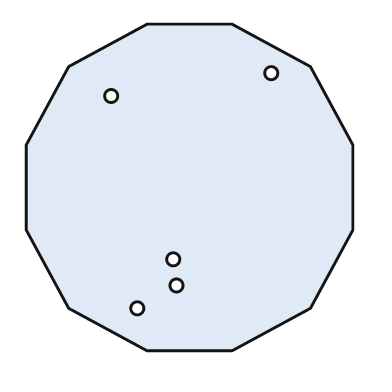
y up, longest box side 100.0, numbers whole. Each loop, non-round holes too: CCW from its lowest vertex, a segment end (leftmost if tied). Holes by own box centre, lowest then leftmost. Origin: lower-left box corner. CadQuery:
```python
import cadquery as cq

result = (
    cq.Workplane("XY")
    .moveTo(37.0, 0.0)
    .lineTo(63.0, 0.0)
    .lineTo(87.0, 13.0)
    .lineTo(100.0, 37.0)
    .lineTo(100.0, 63.0)
    .lineTo(87.0, 87.0)
    .lineTo(63.0, 100.0)
    .lineTo(37.0, 100.0)
    .lineTo(13.0, 87.0)
    .lineTo(0.0, 63.0)
    .lineTo(0.0, 37.0)
    .lineTo(13.0, 13.0)
    .close()
    .moveTo(34.0, 13.0)
    .circle(2.0)
    .moveTo(46.0, 20.0)
    .circle(2.0)
    .moveTo(45.0, 28.0)
    .circle(2.0)
    .moveTo(26.0, 78.0)
    .circle(2.0)
    .moveTo(75.0, 85.0)
    .circle(2.0)
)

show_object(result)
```